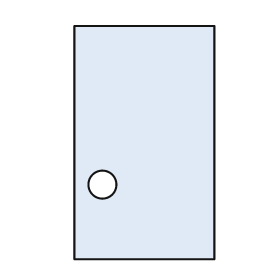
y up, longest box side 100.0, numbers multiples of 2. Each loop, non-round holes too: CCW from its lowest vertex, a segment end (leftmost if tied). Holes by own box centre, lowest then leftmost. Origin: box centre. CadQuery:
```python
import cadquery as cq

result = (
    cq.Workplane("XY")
    .moveTo(-30.0, -50.0)
    .lineTo(30.0, -50.0)
    .lineTo(30.0, 50.0)
    .lineTo(-30.0, 50.0)
    .close()
    .moveTo(-18.0, -18.0)
    .circle(6.0)
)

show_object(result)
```